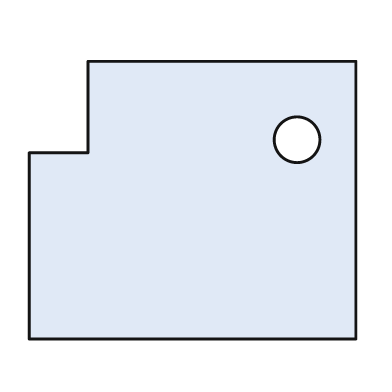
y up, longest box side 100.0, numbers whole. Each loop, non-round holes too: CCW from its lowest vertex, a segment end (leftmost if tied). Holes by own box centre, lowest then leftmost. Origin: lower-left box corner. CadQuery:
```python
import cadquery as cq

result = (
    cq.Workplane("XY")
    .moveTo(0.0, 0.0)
    .lineTo(100.0, 0.0)
    .lineTo(100.0, 85.0)
    .lineTo(18.0, 85.0)
    .lineTo(18.0, 57.0)
    .lineTo(0.0, 57.0)
    .close()
    .moveTo(82.0, 61.0)
    .circle(7.0)
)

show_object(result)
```